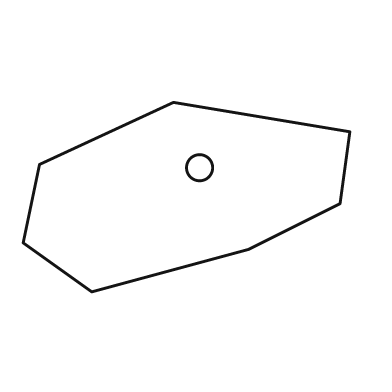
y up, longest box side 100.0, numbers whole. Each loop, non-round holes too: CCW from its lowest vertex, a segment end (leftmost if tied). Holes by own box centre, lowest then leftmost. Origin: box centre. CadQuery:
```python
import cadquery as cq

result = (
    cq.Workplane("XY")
    .moveTo(-29.0, -29.0)
    .lineTo(19.0, -16.0)
    .lineTo(47.0, -2.0)
    .lineTo(50.0, 20.0)
    .lineTo(-4.0, 29.0)
    .lineTo(-45.0, 10.0)
    .lineTo(-50.0, -14.0)
    .close()
    .moveTo(4.0, 9.0)
    .circle(4.0)
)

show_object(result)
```